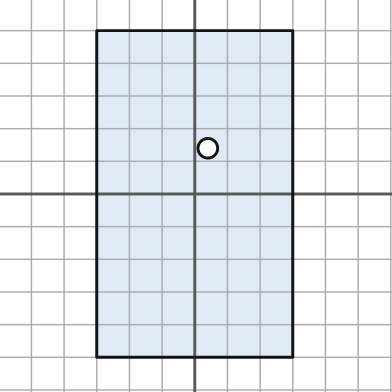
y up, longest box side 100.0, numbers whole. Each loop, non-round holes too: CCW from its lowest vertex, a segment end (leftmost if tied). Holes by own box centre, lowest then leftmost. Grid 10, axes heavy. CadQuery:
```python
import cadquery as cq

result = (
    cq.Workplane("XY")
    .moveTo(-30.0, -50.0)
    .lineTo(30.0, -50.0)
    .lineTo(30.0, 50.0)
    .lineTo(-30.0, 50.0)
    .close()
    .moveTo(4.0, 14.0)
    .circle(3.0)
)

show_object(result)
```